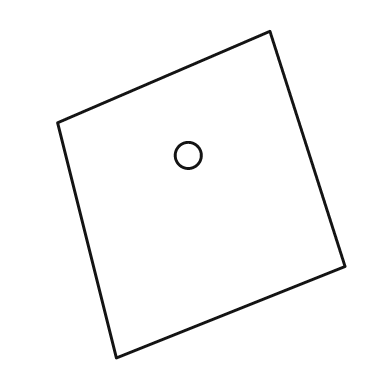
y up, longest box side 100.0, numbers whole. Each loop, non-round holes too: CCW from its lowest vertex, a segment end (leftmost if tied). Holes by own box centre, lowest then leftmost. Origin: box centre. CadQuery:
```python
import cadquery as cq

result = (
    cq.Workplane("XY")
    .moveTo(-26.0, -50.0)
    .lineTo(44.0, -22.0)
    .lineTo(21.0, 50.0)
    .lineTo(-44.0, 22.0)
    .close()
    .moveTo(-4.0, 12.0)
    .circle(4.0)
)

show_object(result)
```